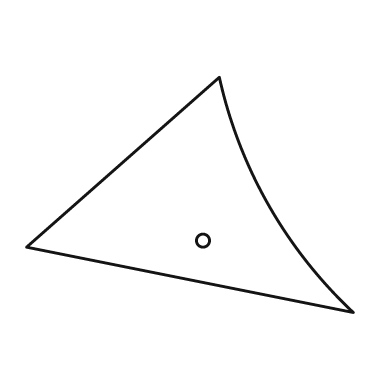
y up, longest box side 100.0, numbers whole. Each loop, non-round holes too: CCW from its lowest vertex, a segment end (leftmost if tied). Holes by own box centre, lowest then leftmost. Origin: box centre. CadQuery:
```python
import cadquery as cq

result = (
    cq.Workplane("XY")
    .moveTo(50.0, -36.0)
    .threePointArc((24.0, -3.0), (9.0, 36.0))
    .lineTo(-50.0, -16.0)
    .close()
    .moveTo(4.0, -14.0)
    .circle(2.0)
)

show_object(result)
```